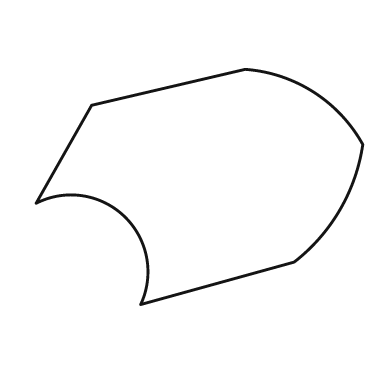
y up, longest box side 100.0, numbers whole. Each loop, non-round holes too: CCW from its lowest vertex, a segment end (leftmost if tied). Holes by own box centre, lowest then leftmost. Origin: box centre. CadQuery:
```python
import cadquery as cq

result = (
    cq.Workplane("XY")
    .moveTo(-18.0, -36.0)
    .lineTo(29.0, -23.0)
    .threePointArc((43.0, -7.0), (50.0, 13.0))
    .threePointArc((35.0, 29.0), (14.0, 36.0))
    .lineTo(-33.0, 25.0)
    .lineTo(-50.0, -5.0)
    .threePointArc((-23.0, -9.0), (-18.0, -36.0))
    .close()
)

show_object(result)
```